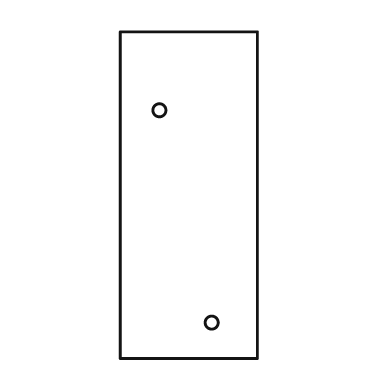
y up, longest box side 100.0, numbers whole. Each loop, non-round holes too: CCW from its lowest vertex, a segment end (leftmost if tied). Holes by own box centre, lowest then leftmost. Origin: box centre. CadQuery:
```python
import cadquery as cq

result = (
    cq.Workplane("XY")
    .moveTo(-21.0, -50.0)
    .lineTo(21.0, -50.0)
    .lineTo(21.0, 50.0)
    .lineTo(-21.0, 50.0)
    .close()
    .moveTo(7.0, -39.0)
    .circle(2.0)
    .moveTo(-9.0, 26.0)
    .circle(2.0)
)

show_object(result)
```